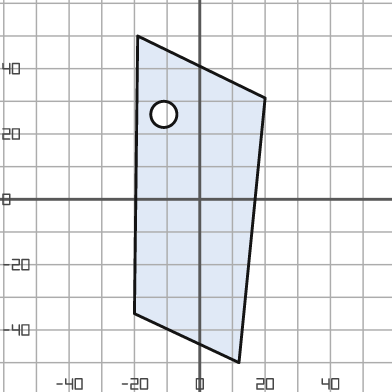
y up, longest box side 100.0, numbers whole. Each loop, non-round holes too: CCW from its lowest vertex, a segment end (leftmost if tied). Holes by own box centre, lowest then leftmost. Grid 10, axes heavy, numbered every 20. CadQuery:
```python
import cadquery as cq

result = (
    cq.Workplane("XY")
    .moveTo(12.0, -50.0)
    .lineTo(20.0, 31.0)
    .lineTo(-19.0, 50.0)
    .lineTo(-20.0, -35.0)
    .close()
    .moveTo(-11.0, 26.0)
    .circle(4.0)
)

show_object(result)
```